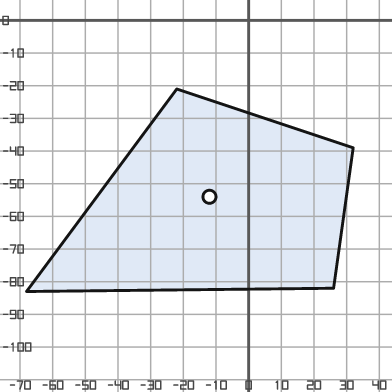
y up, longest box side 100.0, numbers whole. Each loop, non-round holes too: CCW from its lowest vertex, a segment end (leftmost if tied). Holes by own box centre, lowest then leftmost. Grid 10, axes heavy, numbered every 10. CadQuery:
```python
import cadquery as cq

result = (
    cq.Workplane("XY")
    .moveTo(-68.0, -83.0)
    .lineTo(26.0, -82.0)
    .lineTo(32.0, -39.0)
    .lineTo(-22.0, -21.0)
    .close()
    .moveTo(-12.0, -54.0)
    .circle(2.0)
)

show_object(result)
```